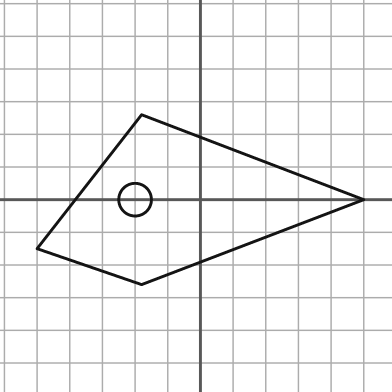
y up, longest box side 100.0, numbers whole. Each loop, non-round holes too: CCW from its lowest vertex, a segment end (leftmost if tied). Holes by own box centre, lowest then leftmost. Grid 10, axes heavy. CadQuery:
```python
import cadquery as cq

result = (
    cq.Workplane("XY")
    .moveTo(-18.0, -26.0)
    .lineTo(50.0, 0.0)
    .lineTo(-18.0, 26.0)
    .lineTo(-50.0, -15.0)
    .close()
    .moveTo(-20.0, 0.0)
    .circle(5.0)
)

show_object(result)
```